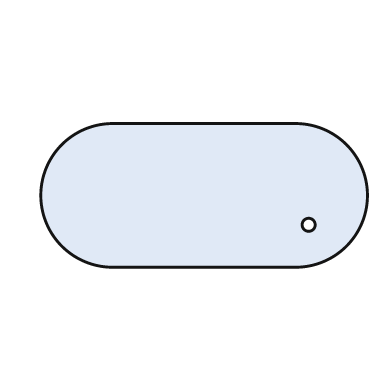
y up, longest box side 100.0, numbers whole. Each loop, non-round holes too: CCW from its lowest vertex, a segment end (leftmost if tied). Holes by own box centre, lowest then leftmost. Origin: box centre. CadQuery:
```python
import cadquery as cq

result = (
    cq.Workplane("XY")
    .moveTo(-28.0, -22.0)
    .lineTo(28.0, -22.0)
    .threePointArc((50.0, 0.0), (28.0, 22.0))
    .lineTo(-28.0, 22.0)
    .threePointArc((-50.0, 0.0), (-28.0, -22.0))
    .close()
    .moveTo(32.0, -9.0)
    .circle(2.0)
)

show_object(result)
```